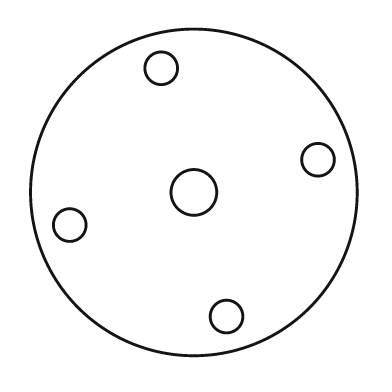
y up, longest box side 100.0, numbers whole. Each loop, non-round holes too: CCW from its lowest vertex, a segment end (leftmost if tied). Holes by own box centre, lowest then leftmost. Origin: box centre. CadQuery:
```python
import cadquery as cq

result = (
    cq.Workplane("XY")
    .moveTo(0.0, 0.0)
    .circle(50.0)
    .moveTo(10.0, -38.0)
    .circle(5.0)
    .moveTo(-38.0, -10.0)
    .circle(5.0)
    .moveTo(0.0, 0.0)
    .circle(7.0)
    .moveTo(38.0, 10.0)
    .circle(5.0)
    .moveTo(-10.0, 38.0)
    .circle(5.0)
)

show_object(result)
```